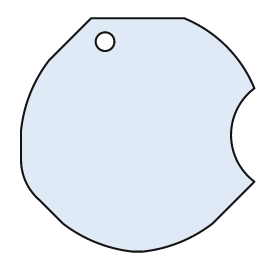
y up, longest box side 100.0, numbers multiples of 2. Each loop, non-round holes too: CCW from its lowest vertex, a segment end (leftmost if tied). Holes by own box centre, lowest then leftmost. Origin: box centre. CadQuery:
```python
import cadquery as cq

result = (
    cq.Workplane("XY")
    .moveTo(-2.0, -50.0)
    .lineTo(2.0, -50.0)
    .threePointArc((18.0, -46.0), (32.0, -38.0))
    .lineTo(50.0, -20.0)
    .threePointArc((40.0, 0.0), (50.0, 20.0))
    .threePointArc((38.0, 38.0), (20.0, 50.0))
    .lineTo(-20.0, 50.0)
    .lineTo(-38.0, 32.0)
    .threePointArc((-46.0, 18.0), (-50.0, 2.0))
    .lineTo(-50.0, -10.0)
    .threePointArc((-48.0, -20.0), (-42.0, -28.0))
    .lineTo(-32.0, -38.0)
    .threePointArc((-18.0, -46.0), (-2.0, -50.0))
    .close()
    .moveTo(-14.0, 40.0)
    .circle(4.0)
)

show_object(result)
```